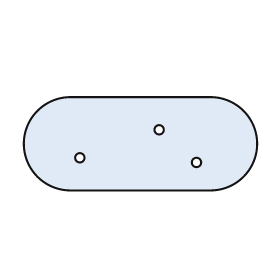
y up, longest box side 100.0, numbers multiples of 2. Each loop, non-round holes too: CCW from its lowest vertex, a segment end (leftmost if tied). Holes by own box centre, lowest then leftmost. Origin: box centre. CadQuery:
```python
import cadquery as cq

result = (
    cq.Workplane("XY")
    .moveTo(-30.0, -20.0)
    .lineTo(30.0, -20.0)
    .threePointArc((50.0, 0.0), (30.0, 20.0))
    .lineTo(-30.0, 20.0)
    .threePointArc((-50.0, 0.0), (-30.0, -20.0))
    .close()
    .moveTo(24.0, -8.0)
    .circle(2.0)
    .moveTo(-26.0, -6.0)
    .circle(2.0)
    .moveTo(8.0, 6.0)
    .circle(2.0)
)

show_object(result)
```